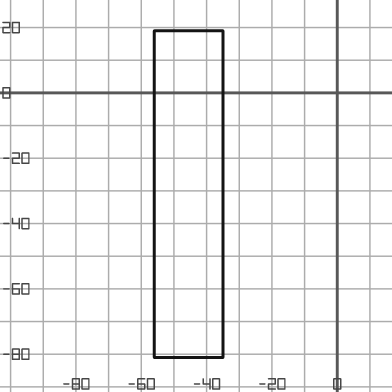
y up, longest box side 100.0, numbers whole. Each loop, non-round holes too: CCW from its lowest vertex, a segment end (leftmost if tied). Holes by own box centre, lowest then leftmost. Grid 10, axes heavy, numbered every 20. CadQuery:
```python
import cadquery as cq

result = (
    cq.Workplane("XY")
    .moveTo(-56.0, -81.0)
    .lineTo(-35.0, -81.0)
    .lineTo(-35.0, 19.0)
    .lineTo(-56.0, 19.0)
    .close()
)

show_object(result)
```